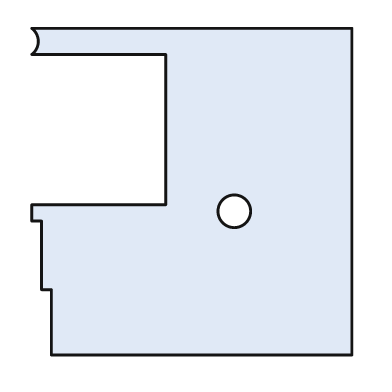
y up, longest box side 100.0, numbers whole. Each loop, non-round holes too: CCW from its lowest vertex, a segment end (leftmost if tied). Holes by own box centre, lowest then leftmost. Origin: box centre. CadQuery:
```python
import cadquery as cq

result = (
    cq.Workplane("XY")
    .moveTo(-43.0, -50.0)
    .lineTo(49.0, -50.0)
    .lineTo(49.0, 50.0)
    .lineTo(-49.0, 50.0)
    .threePointArc((-47.0, 46.0), (-49.0, 42.0))
    .lineTo(-8.0, 42.0)
    .lineTo(-8.0, -4.0)
    .lineTo(-49.0, -4.0)
    .lineTo(-49.0, -9.0)
    .lineTo(-46.0, -9.0)
    .lineTo(-46.0, -30.0)
    .lineTo(-43.0, -30.0)
    .close()
    .moveTo(13.0, -6.0)
    .circle(5.0)
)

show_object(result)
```